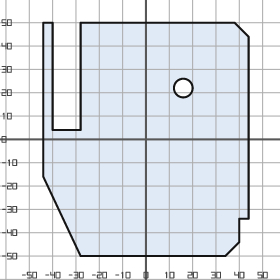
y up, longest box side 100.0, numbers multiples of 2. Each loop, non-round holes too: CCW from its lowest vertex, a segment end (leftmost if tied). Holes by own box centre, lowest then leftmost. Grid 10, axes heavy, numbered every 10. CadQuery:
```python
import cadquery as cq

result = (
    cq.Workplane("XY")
    .moveTo(-28.0, -50.0)
    .lineTo(34.0, -50.0)
    .lineTo(40.0, -44.0)
    .lineTo(40.0, -34.0)
    .lineTo(44.0, -34.0)
    .lineTo(44.0, 44.0)
    .lineTo(38.0, 50.0)
    .lineTo(-28.0, 50.0)
    .lineTo(-28.0, 4.0)
    .lineTo(-40.0, 4.0)
    .lineTo(-40.0, 50.0)
    .lineTo(-44.0, 50.0)
    .lineTo(-44.0, -16.0)
    .close()
    .moveTo(16.0, 22.0)
    .circle(4.0)
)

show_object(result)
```